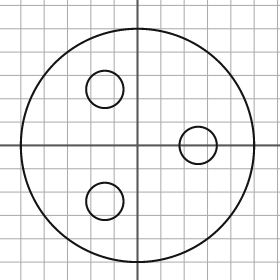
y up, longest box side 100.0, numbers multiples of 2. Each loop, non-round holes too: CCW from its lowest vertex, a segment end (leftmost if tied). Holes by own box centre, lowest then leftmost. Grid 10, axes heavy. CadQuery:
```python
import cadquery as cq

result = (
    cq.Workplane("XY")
    .moveTo(0.0, 0.0)
    .circle(50.0)
    .moveTo(-14.0, -24.0)
    .circle(8.0)
    .moveTo(26.0, 0.0)
    .circle(8.0)
    .moveTo(-14.0, 24.0)
    .circle(8.0)
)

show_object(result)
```